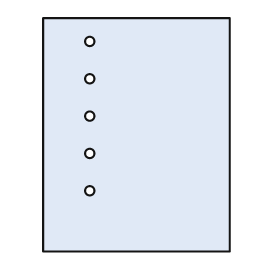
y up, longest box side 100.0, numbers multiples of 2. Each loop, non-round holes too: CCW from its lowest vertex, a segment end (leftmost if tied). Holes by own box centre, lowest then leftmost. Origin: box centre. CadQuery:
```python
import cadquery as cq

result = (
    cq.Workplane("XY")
    .moveTo(-40.0, -50.0)
    .lineTo(40.0, -50.0)
    .lineTo(40.0, 50.0)
    .lineTo(-40.0, 50.0)
    .close()
    .moveTo(-20.0, -24.0)
    .circle(2.0)
    .moveTo(-20.0, -8.0)
    .circle(2.0)
    .moveTo(-20.0, 8.0)
    .circle(2.0)
    .moveTo(-20.0, 24.0)
    .circle(2.0)
    .moveTo(-20.0, 40.0)
    .circle(2.0)
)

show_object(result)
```